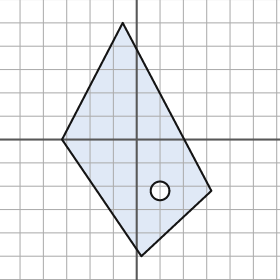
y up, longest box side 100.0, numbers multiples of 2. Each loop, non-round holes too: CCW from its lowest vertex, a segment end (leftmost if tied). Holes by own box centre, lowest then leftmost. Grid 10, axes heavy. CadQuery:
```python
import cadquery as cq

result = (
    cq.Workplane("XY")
    .moveTo(2.0, -50.0)
    .lineTo(32.0, -22.0)
    .lineTo(-6.0, 50.0)
    .lineTo(-32.0, 0.0)
    .close()
    .moveTo(10.0, -22.0)
    .circle(4.0)
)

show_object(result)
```